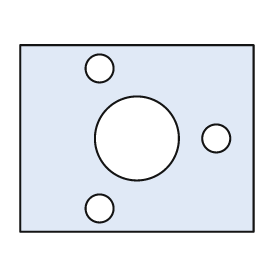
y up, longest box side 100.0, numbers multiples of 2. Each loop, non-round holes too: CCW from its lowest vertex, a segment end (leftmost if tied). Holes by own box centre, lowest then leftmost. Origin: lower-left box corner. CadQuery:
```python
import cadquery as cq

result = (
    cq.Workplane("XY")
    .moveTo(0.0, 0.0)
    .lineTo(100.0, 0.0)
    .lineTo(100.0, 80.0)
    .lineTo(0.0, 80.0)
    .close()
    .moveTo(34.0, 10.0)
    .circle(6.0)
    .moveTo(50.0, 40.0)
    .circle(18.0)
    .moveTo(84.0, 40.0)
    .circle(6.0)
    .moveTo(34.0, 70.0)
    .circle(6.0)
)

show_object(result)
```